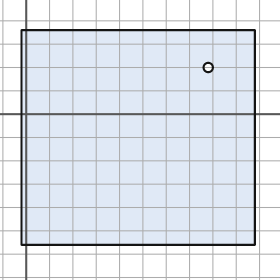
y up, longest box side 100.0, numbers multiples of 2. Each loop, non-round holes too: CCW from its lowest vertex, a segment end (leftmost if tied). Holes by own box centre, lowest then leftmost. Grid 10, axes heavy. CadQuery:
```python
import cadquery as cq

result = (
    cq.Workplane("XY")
    .moveTo(-2.0, -56.0)
    .lineTo(98.0, -56.0)
    .lineTo(98.0, 36.0)
    .lineTo(-2.0, 36.0)
    .close()
    .moveTo(78.0, 20.0)
    .circle(2.0)
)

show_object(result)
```